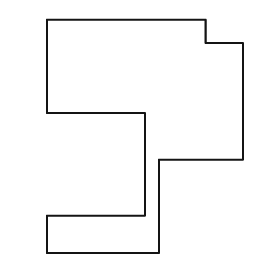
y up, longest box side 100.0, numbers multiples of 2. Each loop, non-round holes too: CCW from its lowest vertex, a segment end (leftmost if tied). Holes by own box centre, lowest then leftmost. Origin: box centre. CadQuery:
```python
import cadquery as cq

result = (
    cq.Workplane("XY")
    .moveTo(-42.0, -50.0)
    .lineTo(6.0, -50.0)
    .lineTo(6.0, -10.0)
    .lineTo(42.0, -10.0)
    .lineTo(42.0, 40.0)
    .lineTo(26.0, 40.0)
    .lineTo(26.0, 50.0)
    .lineTo(-42.0, 50.0)
    .lineTo(-42.0, 10.0)
    .lineTo(0.0, 10.0)
    .lineTo(0.0, -34.0)
    .lineTo(-42.0, -34.0)
    .close()
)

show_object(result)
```